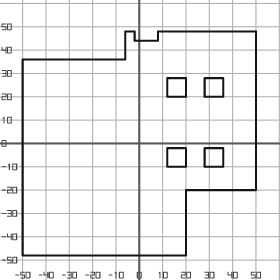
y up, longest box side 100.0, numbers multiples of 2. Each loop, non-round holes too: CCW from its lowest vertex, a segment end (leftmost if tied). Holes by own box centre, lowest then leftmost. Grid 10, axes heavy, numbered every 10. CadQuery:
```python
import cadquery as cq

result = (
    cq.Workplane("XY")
    .moveTo(-50.0, -48.0)
    .lineTo(20.0, -48.0)
    .lineTo(20.0, -20.0)
    .lineTo(50.0, -20.0)
    .lineTo(50.0, 48.0)
    .lineTo(8.0, 48.0)
    .lineTo(8.0, 44.0)
    .lineTo(-2.0, 44.0)
    .lineTo(-2.0, 48.0)
    .lineTo(-6.0, 48.0)
    .lineTo(-6.0, 36.0)
    .lineTo(-50.0, 36.0)
    .close()
    .moveTo(12.0, -10.0)
    .lineTo(20.0, -10.0)
    .lineTo(20.0, -2.0)
    .lineTo(12.0, -2.0)
    .close()
    .moveTo(28.0, -10.0)
    .lineTo(36.0, -10.0)
    .lineTo(36.0, -2.0)
    .lineTo(28.0, -2.0)
    .close()
    .moveTo(12.0, 20.0)
    .lineTo(20.0, 20.0)
    .lineTo(20.0, 28.0)
    .lineTo(12.0, 28.0)
    .close()
    .moveTo(28.0, 20.0)
    .lineTo(36.0, 20.0)
    .lineTo(36.0, 28.0)
    .lineTo(28.0, 28.0)
    .close()
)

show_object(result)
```